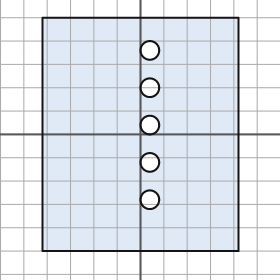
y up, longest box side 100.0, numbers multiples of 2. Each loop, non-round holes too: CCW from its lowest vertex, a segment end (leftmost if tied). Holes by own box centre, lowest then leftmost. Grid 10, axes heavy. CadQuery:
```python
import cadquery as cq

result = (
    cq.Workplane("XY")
    .moveTo(-42.0, -50.0)
    .lineTo(42.0, -50.0)
    .lineTo(42.0, 50.0)
    .lineTo(-42.0, 50.0)
    .close()
    .moveTo(4.0, -28.0)
    .circle(4.0)
    .moveTo(4.0, -12.0)
    .circle(4.0)
    .moveTo(4.0, 4.0)
    .circle(4.0)
    .moveTo(4.0, 20.0)
    .circle(4.0)
    .moveTo(4.0, 36.0)
    .circle(4.0)
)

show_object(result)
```